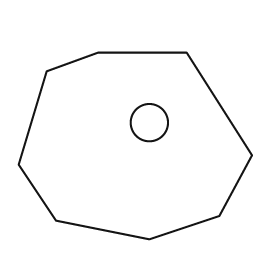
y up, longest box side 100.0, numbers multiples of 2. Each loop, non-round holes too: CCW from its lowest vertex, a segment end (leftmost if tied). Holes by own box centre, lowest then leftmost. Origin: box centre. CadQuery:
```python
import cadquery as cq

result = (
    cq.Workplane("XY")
    .moveTo(6.0, -40.0)
    .lineTo(36.0, -30.0)
    .lineTo(50.0, -4.0)
    .lineTo(22.0, 40.0)
    .lineTo(-16.0, 40.0)
    .lineTo(-38.0, 32.0)
    .lineTo(-50.0, -8.0)
    .lineTo(-34.0, -32.0)
    .close()
    .moveTo(6.0, 10.0)
    .circle(8.0)
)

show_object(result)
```